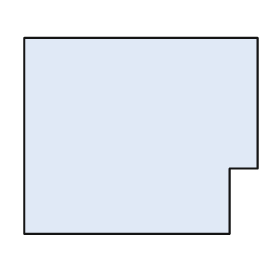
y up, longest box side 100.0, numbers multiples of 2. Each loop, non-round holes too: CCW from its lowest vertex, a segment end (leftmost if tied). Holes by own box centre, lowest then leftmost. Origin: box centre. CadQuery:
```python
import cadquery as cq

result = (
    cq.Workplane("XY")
    .moveTo(-50.0, -42.0)
    .lineTo(38.0, -42.0)
    .lineTo(38.0, -14.0)
    .lineTo(50.0, -14.0)
    .lineTo(50.0, 42.0)
    .lineTo(-50.0, 42.0)
    .close()
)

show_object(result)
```